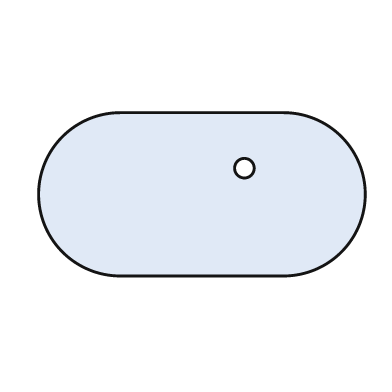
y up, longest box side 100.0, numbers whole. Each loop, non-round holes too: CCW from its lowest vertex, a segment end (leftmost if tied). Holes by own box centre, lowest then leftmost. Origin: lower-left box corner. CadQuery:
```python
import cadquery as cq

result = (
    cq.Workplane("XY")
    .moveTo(25.0, 0.0)
    .lineTo(75.0, 0.0)
    .threePointArc((100.0, 25.0), (75.0, 50.0))
    .lineTo(25.0, 50.0)
    .threePointArc((0.0, 25.0), (25.0, 0.0))
    .close()
    .moveTo(63.0, 33.0)
    .circle(3.0)
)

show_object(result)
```